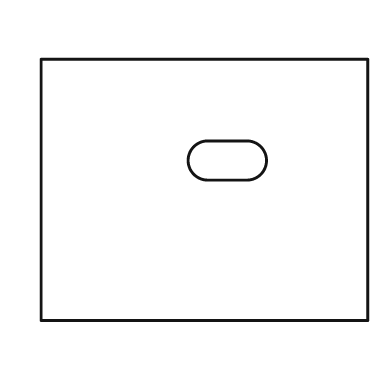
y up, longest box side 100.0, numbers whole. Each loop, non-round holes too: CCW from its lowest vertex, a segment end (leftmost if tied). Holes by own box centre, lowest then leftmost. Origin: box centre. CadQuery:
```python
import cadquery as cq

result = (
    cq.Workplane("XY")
    .moveTo(-50.0, -40.0)
    .lineTo(50.0, -40.0)
    .lineTo(50.0, 40.0)
    .lineTo(-50.0, 40.0)
    .close()
    .moveTo(1.0, 3.0)
    .lineTo(13.0, 3.0)
    .threePointArc((19.0, 9.0), (13.0, 15.0))
    .lineTo(1.0, 15.0)
    .threePointArc((-5.0, 9.0), (1.0, 3.0))
    .close()
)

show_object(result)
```